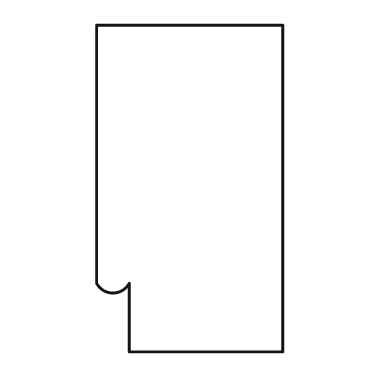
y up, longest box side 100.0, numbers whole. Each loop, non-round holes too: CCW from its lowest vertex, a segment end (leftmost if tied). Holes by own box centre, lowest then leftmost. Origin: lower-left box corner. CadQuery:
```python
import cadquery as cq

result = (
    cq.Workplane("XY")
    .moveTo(10.0, 0.0)
    .lineTo(57.0, 0.0)
    .lineTo(57.0, 100.0)
    .lineTo(0.0, 100.0)
    .lineTo(0.0, 21.0)
    .threePointArc((5.0, 18.0), (10.0, 21.0))
    .close()
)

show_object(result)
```